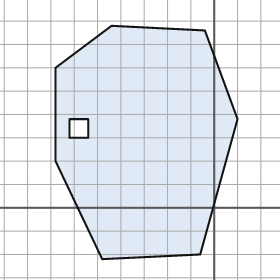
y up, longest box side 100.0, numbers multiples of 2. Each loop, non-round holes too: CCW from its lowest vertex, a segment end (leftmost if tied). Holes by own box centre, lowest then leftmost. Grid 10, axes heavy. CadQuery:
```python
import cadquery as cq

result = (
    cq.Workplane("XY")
    .moveTo(-48.0, -22.0)
    .lineTo(-6.0, -20.0)
    .lineTo(10.0, 38.0)
    .lineTo(-4.0, 76.0)
    .lineTo(-44.0, 78.0)
    .lineTo(-68.0, 60.0)
    .lineTo(-68.0, 20.0)
    .close()
    .moveTo(-62.0, 30.0)
    .lineTo(-54.0, 30.0)
    .lineTo(-54.0, 38.0)
    .lineTo(-62.0, 38.0)
    .close()
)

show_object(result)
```